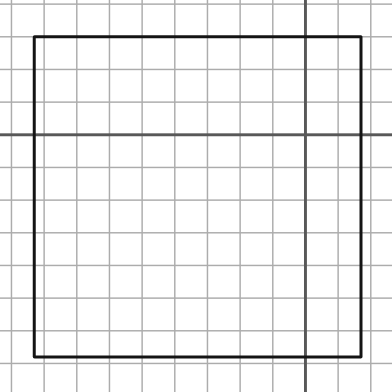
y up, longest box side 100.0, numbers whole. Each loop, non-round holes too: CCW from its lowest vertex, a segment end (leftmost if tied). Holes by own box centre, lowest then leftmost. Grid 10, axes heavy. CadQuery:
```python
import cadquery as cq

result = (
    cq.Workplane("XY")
    .moveTo(-83.0, -68.0)
    .lineTo(17.0, -68.0)
    .lineTo(17.0, 30.0)
    .lineTo(-83.0, 30.0)
    .close()
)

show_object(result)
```